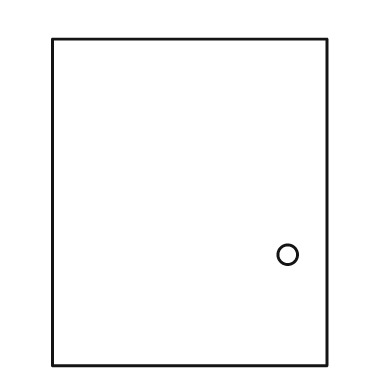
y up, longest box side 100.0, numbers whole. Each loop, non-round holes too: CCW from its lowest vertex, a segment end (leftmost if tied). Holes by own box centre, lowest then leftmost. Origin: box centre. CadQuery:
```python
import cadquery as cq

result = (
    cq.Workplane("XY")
    .moveTo(-42.0, -50.0)
    .lineTo(42.0, -50.0)
    .lineTo(42.0, 50.0)
    .lineTo(-42.0, 50.0)
    .close()
    .moveTo(30.0, -16.0)
    .circle(3.0)
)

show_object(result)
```